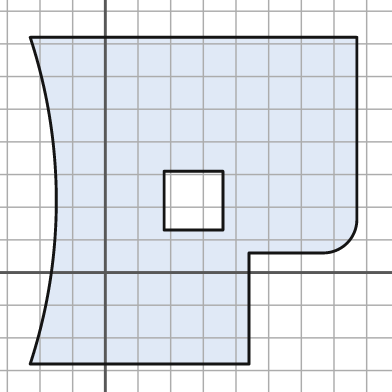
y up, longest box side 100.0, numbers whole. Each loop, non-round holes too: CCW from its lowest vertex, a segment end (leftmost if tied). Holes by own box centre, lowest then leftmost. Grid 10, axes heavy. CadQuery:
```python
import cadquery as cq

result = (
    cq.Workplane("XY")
    .moveTo(-23.0, -28.0)
    .lineTo(44.0, -28.0)
    .lineTo(44.0, 6.0)
    .lineTo(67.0, 6.0)
    .threePointArc((74.0, 9.0), (77.0, 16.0))
    .lineTo(77.0, 72.0)
    .lineTo(-23.0, 72.0)
    .threePointArc((-15.0, 22.0), (-23.0, -28.0))
    .close()
    .moveTo(18.0, 13.0)
    .lineTo(36.0, 13.0)
    .lineTo(36.0, 31.0)
    .lineTo(18.0, 31.0)
    .close()
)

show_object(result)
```